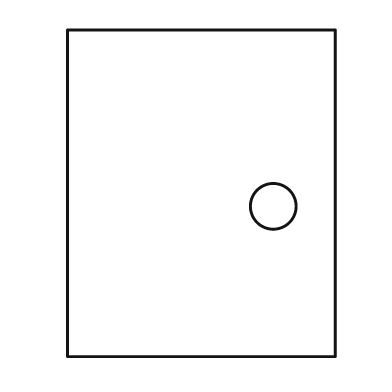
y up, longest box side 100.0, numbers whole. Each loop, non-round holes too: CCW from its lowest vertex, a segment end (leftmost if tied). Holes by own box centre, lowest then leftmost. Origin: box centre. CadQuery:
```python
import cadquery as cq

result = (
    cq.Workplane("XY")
    .moveTo(-41.0, -50.0)
    .lineTo(41.0, -50.0)
    .lineTo(41.0, 50.0)
    .lineTo(-41.0, 50.0)
    .close()
    .moveTo(22.0, -4.0)
    .circle(7.0)
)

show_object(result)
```